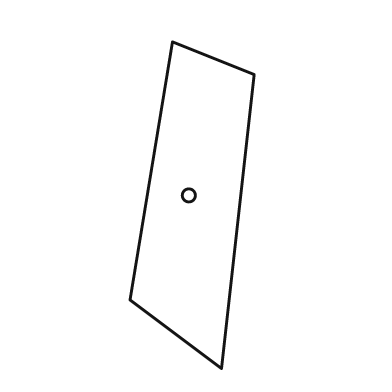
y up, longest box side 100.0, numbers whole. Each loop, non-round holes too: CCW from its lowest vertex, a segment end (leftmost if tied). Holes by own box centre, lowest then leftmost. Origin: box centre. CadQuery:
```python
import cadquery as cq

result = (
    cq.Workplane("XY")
    .moveTo(9.0, -50.0)
    .lineTo(19.0, 40.0)
    .lineTo(-6.0, 50.0)
    .lineTo(-19.0, -29.0)
    .close()
    .moveTo(-1.0, 3.0)
    .circle(2.0)
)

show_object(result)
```